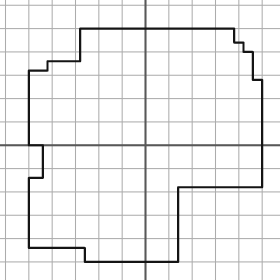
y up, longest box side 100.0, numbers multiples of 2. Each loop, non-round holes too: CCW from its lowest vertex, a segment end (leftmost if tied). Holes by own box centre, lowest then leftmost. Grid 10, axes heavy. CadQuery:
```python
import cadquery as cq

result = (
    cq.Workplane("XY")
    .moveTo(-26.0, -50.0)
    .lineTo(14.0, -50.0)
    .lineTo(14.0, -18.0)
    .lineTo(50.0, -18.0)
    .lineTo(50.0, 28.0)
    .lineTo(46.0, 28.0)
    .lineTo(46.0, 40.0)
    .lineTo(42.0, 40.0)
    .lineTo(42.0, 44.0)
    .lineTo(38.0, 44.0)
    .lineTo(38.0, 50.0)
    .lineTo(-28.0, 50.0)
    .lineTo(-28.0, 36.0)
    .lineTo(-42.0, 36.0)
    .lineTo(-42.0, 32.0)
    .lineTo(-50.0, 32.0)
    .lineTo(-50.0, 0.0)
    .lineTo(-44.0, 0.0)
    .lineTo(-44.0, -14.0)
    .lineTo(-50.0, -14.0)
    .lineTo(-50.0, -44.0)
    .lineTo(-26.0, -44.0)
    .close()
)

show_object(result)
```